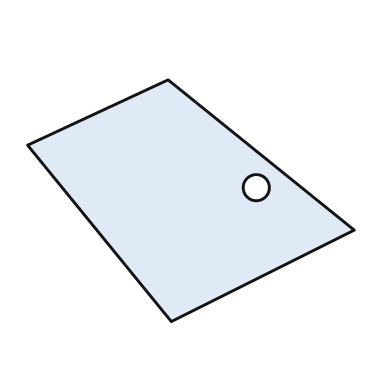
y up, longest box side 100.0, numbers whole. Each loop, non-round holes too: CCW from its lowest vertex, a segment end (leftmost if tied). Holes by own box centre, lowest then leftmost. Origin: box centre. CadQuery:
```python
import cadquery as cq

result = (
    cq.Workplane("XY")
    .moveTo(-6.0, -37.0)
    .lineTo(50.0, -9.0)
    .lineTo(-7.0, 37.0)
    .lineTo(-50.0, 17.0)
    .close()
    .moveTo(20.0, 4.0)
    .circle(4.0)
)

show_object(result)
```